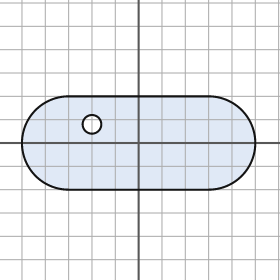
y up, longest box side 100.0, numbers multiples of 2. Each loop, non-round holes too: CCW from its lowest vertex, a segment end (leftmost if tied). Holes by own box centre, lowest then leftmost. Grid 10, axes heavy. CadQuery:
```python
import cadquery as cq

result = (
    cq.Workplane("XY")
    .moveTo(-30.0, -20.0)
    .lineTo(30.0, -20.0)
    .threePointArc((50.0, 0.0), (30.0, 20.0))
    .lineTo(-30.0, 20.0)
    .threePointArc((-50.0, 0.0), (-30.0, -20.0))
    .close()
    .moveTo(-20.0, 8.0)
    .circle(4.0)
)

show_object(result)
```